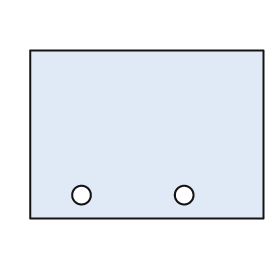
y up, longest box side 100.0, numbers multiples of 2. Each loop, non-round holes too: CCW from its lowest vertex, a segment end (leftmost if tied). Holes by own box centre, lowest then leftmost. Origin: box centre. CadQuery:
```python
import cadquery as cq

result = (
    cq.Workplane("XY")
    .moveTo(-50.0, -36.0)
    .lineTo(50.0, -36.0)
    .lineTo(50.0, 36.0)
    .lineTo(-50.0, 36.0)
    .close()
    .moveTo(-28.0, -26.0)
    .circle(4.0)
    .moveTo(16.0, -26.0)
    .circle(4.0)
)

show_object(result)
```